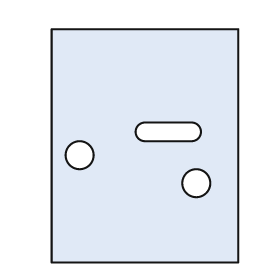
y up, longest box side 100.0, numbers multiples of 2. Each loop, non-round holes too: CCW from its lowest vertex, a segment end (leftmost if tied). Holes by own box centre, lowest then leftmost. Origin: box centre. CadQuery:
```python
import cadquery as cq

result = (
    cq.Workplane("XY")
    .moveTo(-40.0, -50.0)
    .lineTo(40.0, -50.0)
    .lineTo(40.0, 50.0)
    .lineTo(-40.0, 50.0)
    .close()
    .moveTo(22.0, -16.0)
    .circle(6.0)
    .moveTo(-28.0, -4.0)
    .circle(6.0)
    .moveTo(0.0, 2.0)
    .lineTo(20.0, 2.0)
    .threePointArc((24.0, 6.0), (20.0, 10.0))
    .lineTo(0.0, 10.0)
    .threePointArc((-4.0, 6.0), (0.0, 2.0))
    .close()
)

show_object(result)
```